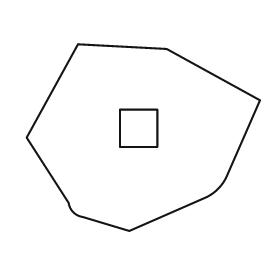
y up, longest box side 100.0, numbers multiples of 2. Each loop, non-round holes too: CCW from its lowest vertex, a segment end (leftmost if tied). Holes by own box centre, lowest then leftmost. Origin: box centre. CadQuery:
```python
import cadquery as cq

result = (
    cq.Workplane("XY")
    .moveTo(-6.0, -40.0)
    .lineTo(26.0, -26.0)
    .threePointArc((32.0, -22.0), (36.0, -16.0))
    .lineTo(50.0, 16.0)
    .lineTo(10.0, 38.0)
    .lineTo(-28.0, 40.0)
    .lineTo(-50.0, 0.0)
    .lineTo(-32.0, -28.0)
    .threePointArc((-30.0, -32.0), (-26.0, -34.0))
    .close()
    .moveTo(-10.0, -4.0)
    .lineTo(6.0, -4.0)
    .lineTo(6.0, 12.0)
    .lineTo(-10.0, 12.0)
    .close()
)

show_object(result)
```